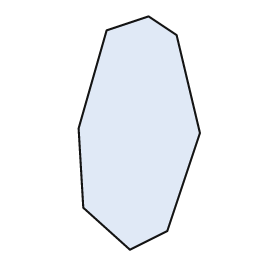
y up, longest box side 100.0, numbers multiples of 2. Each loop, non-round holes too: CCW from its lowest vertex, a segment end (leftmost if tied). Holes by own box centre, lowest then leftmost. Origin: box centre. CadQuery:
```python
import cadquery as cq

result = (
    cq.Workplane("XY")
    .moveTo(-4.0, -50.0)
    .lineTo(12.0, -42.0)
    .lineTo(26.0, 0.0)
    .lineTo(16.0, 42.0)
    .lineTo(4.0, 50.0)
    .lineTo(-14.0, 44.0)
    .lineTo(-26.0, 2.0)
    .lineTo(-24.0, -32.0)
    .close()
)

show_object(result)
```